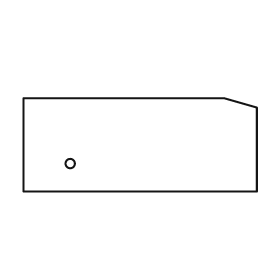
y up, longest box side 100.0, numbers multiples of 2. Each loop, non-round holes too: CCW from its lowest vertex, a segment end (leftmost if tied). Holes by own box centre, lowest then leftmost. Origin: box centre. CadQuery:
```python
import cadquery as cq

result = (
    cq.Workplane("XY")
    .moveTo(-50.0, -20.0)
    .lineTo(50.0, -20.0)
    .lineTo(50.0, 16.0)
    .lineTo(36.0, 20.0)
    .lineTo(-50.0, 20.0)
    .close()
    .moveTo(-30.0, -8.0)
    .circle(2.0)
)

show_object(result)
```